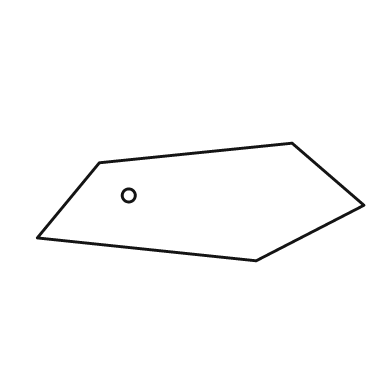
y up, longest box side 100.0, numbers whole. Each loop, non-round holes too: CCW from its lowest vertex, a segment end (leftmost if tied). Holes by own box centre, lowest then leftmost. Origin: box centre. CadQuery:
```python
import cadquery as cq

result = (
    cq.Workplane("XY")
    .moveTo(17.0, -18.0)
    .lineTo(50.0, -1.0)
    .lineTo(28.0, 18.0)
    .lineTo(-31.0, 12.0)
    .lineTo(-50.0, -11.0)
    .close()
    .moveTo(-22.0, 2.0)
    .circle(2.0)
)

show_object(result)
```